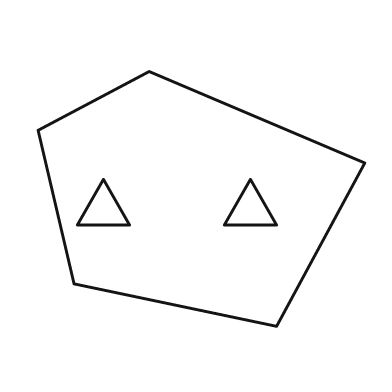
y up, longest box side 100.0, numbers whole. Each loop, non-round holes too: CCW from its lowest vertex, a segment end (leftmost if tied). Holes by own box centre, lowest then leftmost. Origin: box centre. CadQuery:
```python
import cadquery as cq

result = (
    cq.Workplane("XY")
    .moveTo(23.0, -39.0)
    .lineTo(50.0, 11.0)
    .lineTo(-16.0, 39.0)
    .lineTo(-50.0, 21.0)
    .lineTo(-39.0, -26.0)
    .close()
    .moveTo(-38.0, -8.0)
    .lineTo(-22.0, -8.0)
    .lineTo(-30.0, 6.0)
    .close()
    .moveTo(7.0, -8.0)
    .lineTo(23.0, -8.0)
    .lineTo(15.0, 6.0)
    .close()
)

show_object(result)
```